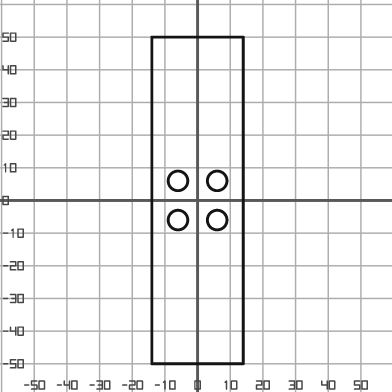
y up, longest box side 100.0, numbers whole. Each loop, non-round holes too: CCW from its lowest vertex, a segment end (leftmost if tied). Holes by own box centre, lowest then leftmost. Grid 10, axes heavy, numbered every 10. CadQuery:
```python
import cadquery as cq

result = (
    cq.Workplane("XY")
    .moveTo(-14.0, -50.0)
    .lineTo(14.0, -50.0)
    .lineTo(14.0, 50.0)
    .lineTo(-14.0, 50.0)
    .close()
    .moveTo(-6.0, -6.0)
    .circle(3.0)
    .moveTo(6.0, -6.0)
    .circle(3.0)
    .moveTo(-6.0, 6.0)
    .circle(3.0)
    .moveTo(6.0, 6.0)
    .circle(3.0)
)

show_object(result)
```